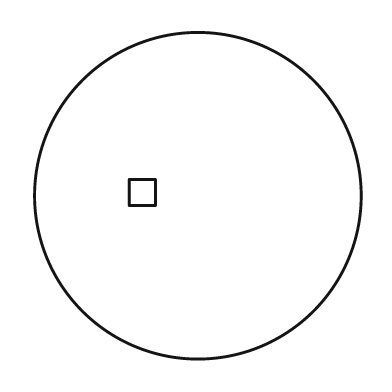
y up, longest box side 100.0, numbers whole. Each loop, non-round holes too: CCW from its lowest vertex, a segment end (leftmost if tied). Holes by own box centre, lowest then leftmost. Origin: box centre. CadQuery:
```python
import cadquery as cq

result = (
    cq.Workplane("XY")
    .moveTo(0.0, 0.0)
    .circle(50.0)
    .moveTo(-21.0, -3.0)
    .lineTo(-13.0, -3.0)
    .lineTo(-13.0, 5.0)
    .lineTo(-21.0, 5.0)
    .close()
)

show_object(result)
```